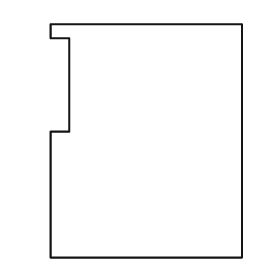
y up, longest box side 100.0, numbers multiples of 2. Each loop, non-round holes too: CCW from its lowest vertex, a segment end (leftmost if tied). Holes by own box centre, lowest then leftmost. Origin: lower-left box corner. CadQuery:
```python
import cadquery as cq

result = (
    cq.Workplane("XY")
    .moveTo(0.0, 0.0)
    .lineTo(82.0, 0.0)
    .lineTo(82.0, 100.0)
    .lineTo(0.0, 100.0)
    .lineTo(0.0, 94.0)
    .lineTo(8.0, 94.0)
    .lineTo(8.0, 54.0)
    .lineTo(0.0, 54.0)
    .close()
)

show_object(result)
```